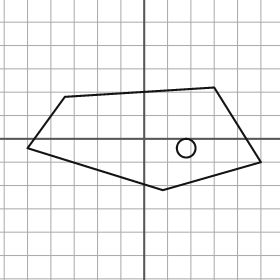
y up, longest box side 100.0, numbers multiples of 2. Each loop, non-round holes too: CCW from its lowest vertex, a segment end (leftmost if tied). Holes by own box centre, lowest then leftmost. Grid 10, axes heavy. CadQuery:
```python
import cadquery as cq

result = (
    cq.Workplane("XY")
    .moveTo(8.0, -22.0)
    .lineTo(50.0, -10.0)
    .lineTo(30.0, 22.0)
    .lineTo(-34.0, 18.0)
    .lineTo(-50.0, -4.0)
    .close()
    .moveTo(18.0, -4.0)
    .circle(4.0)
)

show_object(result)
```